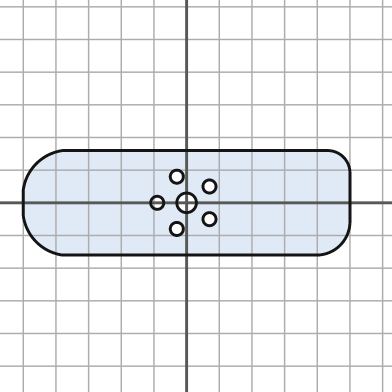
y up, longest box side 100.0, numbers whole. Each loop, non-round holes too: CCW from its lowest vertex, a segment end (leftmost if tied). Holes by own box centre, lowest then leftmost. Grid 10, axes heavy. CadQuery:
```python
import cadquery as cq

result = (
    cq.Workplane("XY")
    .moveTo(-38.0, -16.0)
    .lineTo(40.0, -16.0)
    .threePointArc((47.0, -13.0), (50.0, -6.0))
    .lineTo(50.0, 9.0)
    .threePointArc((48.0, 14.0), (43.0, 16.0))
    .lineTo(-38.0, 16.0)
    .threePointArc((-46.0, 12.0), (-50.0, 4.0))
    .lineTo(-50.0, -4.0)
    .threePointArc((-46.0, -12.0), (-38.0, -16.0))
    .close()
    .moveTo(-3.0, -8.0)
    .circle(2.0)
    .moveTo(7.0, -5.0)
    .circle(2.0)
    .moveTo(-9.0, 0.0)
    .circle(2.0)
    .moveTo(0.0, 0.0)
    .circle(3.0)
    .moveTo(7.0, 5.0)
    .circle(2.0)
    .moveTo(-3.0, 8.0)
    .circle(2.0)
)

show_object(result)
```